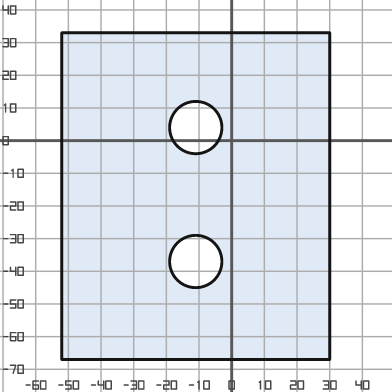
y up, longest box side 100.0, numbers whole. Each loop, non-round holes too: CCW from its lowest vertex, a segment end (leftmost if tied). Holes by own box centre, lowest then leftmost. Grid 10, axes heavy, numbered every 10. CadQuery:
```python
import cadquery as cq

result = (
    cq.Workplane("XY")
    .moveTo(-52.0, -67.0)
    .lineTo(30.0, -67.0)
    .lineTo(30.0, 33.0)
    .lineTo(-52.0, 33.0)
    .close()
    .moveTo(-11.0, -37.0)
    .circle(8.0)
    .moveTo(-11.0, 4.0)
    .circle(8.0)
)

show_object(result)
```